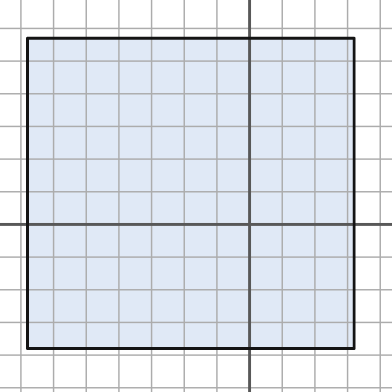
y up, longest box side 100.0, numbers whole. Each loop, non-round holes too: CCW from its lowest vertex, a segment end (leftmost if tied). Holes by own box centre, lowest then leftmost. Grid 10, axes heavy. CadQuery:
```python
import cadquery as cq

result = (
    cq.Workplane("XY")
    .moveTo(-68.0, -38.0)
    .lineTo(32.0, -38.0)
    .lineTo(32.0, 57.0)
    .lineTo(-68.0, 57.0)
    .close()
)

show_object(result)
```